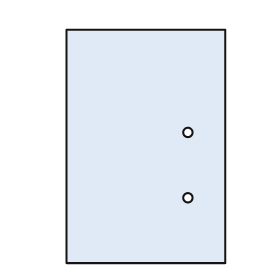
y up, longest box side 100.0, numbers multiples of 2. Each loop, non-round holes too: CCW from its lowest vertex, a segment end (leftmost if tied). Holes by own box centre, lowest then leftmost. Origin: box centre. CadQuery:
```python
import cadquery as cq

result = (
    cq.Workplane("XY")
    .moveTo(-34.0, -50.0)
    .lineTo(34.0, -50.0)
    .lineTo(34.0, 50.0)
    .lineTo(-34.0, 50.0)
    .close()
    .moveTo(18.0, -22.0)
    .circle(2.0)
    .moveTo(18.0, 6.0)
    .circle(2.0)
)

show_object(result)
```